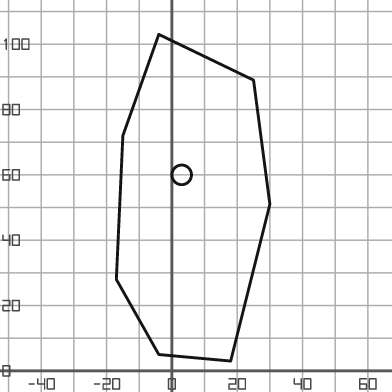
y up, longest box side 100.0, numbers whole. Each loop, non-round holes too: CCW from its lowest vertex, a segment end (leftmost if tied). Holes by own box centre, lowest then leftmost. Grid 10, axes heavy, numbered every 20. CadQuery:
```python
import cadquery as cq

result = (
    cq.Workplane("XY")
    .moveTo(18.0, 3.0)
    .lineTo(30.0, 51.0)
    .lineTo(25.0, 89.0)
    .lineTo(-4.0, 103.0)
    .lineTo(-15.0, 72.0)
    .lineTo(-17.0, 28.0)
    .lineTo(-4.0, 5.0)
    .close()
    .moveTo(3.0, 60.0)
    .circle(3.0)
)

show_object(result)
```